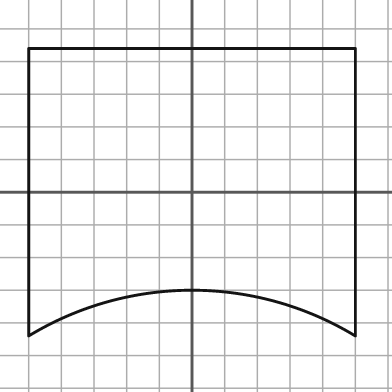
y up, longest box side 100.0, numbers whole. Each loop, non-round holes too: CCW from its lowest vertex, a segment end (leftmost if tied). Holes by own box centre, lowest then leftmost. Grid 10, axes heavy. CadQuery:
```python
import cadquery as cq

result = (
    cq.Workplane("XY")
    .moveTo(-50.0, -44.0)
    .threePointArc((0.0, -30.0), (50.0, -44.0))
    .lineTo(50.0, 44.0)
    .lineTo(-50.0, 44.0)
    .close()
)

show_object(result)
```